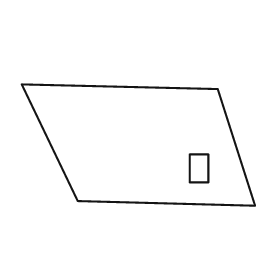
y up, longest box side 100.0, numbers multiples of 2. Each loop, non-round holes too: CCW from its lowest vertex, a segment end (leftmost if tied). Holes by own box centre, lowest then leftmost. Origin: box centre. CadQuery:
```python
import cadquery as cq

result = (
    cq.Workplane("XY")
    .moveTo(50.0, -26.0)
    .lineTo(34.0, 24.0)
    .lineTo(-50.0, 26.0)
    .lineTo(-26.0, -24.0)
    .close()
    .moveTo(22.0, -16.0)
    .lineTo(30.0, -16.0)
    .lineTo(30.0, -4.0)
    .lineTo(22.0, -4.0)
    .close()
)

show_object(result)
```